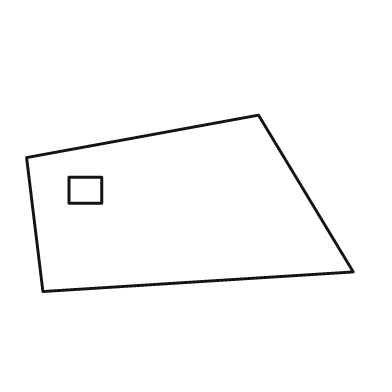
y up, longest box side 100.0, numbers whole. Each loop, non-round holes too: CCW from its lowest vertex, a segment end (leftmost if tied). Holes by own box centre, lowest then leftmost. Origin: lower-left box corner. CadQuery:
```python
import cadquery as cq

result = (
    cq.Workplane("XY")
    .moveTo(5.0, 0.0)
    .lineTo(100.0, 6.0)
    .lineTo(71.0, 54.0)
    .lineTo(0.0, 41.0)
    .close()
    .moveTo(13.0, 27.0)
    .lineTo(23.0, 27.0)
    .lineTo(23.0, 35.0)
    .lineTo(13.0, 35.0)
    .close()
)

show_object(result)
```